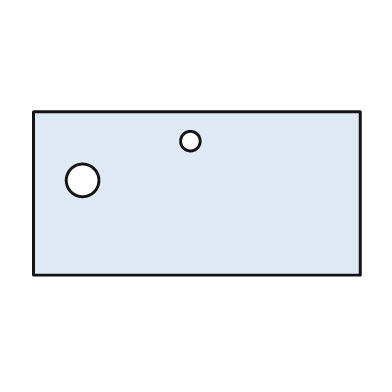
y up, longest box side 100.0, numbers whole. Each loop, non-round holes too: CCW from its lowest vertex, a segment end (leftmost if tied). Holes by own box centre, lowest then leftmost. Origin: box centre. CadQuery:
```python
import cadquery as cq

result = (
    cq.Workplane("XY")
    .moveTo(-50.0, -25.0)
    .lineTo(50.0, -25.0)
    .lineTo(50.0, 25.0)
    .lineTo(-50.0, 25.0)
    .close()
    .moveTo(-35.0, 4.0)
    .circle(5.0)
    .moveTo(-2.0, 16.0)
    .circle(3.0)
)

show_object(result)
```